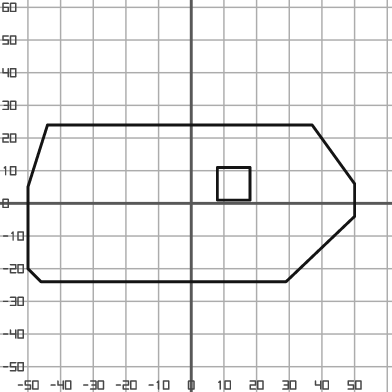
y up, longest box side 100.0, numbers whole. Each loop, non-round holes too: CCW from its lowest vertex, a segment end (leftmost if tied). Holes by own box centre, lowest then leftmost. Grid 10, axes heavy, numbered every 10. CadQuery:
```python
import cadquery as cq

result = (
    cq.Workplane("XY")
    .moveTo(-46.0, -24.0)
    .lineTo(29.0, -24.0)
    .lineTo(50.0, -4.0)
    .lineTo(50.0, 6.0)
    .lineTo(37.0, 24.0)
    .lineTo(-44.0, 24.0)
    .lineTo(-50.0, 5.0)
    .lineTo(-50.0, -20.0)
    .close()
    .moveTo(8.0, 1.0)
    .lineTo(18.0, 1.0)
    .lineTo(18.0, 11.0)
    .lineTo(8.0, 11.0)
    .close()
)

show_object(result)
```